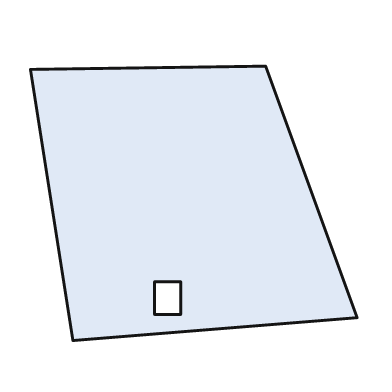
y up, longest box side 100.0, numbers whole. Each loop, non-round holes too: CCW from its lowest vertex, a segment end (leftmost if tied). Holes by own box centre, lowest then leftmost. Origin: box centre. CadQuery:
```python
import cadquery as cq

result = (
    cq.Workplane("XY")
    .moveTo(-37.0, -42.0)
    .lineTo(50.0, -35.0)
    .lineTo(22.0, 42.0)
    .lineTo(-50.0, 41.0)
    .close()
    .moveTo(-12.0, -34.0)
    .lineTo(-4.0, -34.0)
    .lineTo(-4.0, -24.0)
    .lineTo(-12.0, -24.0)
    .close()
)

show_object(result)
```